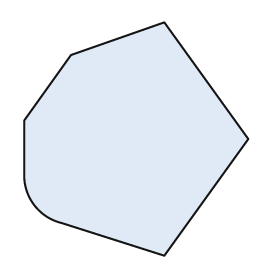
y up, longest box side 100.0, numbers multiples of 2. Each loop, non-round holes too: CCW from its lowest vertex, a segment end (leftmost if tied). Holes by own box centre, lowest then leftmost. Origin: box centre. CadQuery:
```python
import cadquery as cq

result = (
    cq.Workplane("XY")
    .moveTo(12.0, -50.0)
    .lineTo(48.0, 0.0)
    .lineTo(12.0, 50.0)
    .lineTo(-28.0, 36.0)
    .lineTo(-48.0, 8.0)
    .lineTo(-48.0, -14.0)
    .threePointArc((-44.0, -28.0), (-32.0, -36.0))
    .close()
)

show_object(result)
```